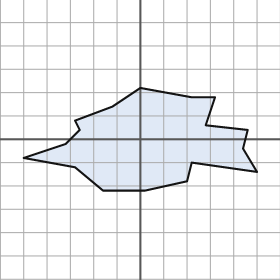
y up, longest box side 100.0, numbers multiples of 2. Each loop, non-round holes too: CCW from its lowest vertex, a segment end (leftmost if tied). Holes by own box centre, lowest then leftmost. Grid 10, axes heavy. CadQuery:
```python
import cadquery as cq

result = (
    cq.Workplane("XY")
    .moveTo(-16.0, -22.0)
    .lineTo(2.0, -22.0)
    .lineTo(20.0, -18.0)
    .lineTo(22.0, -10.0)
    .lineTo(50.0, -14.0)
    .lineTo(44.0, -4.0)
    .lineTo(46.0, 4.0)
    .lineTo(28.0, 6.0)
    .lineTo(32.0, 18.0)
    .lineTo(22.0, 18.0)
    .lineTo(0.0, 22.0)
    .lineTo(-12.0, 14.0)
    .lineTo(-28.0, 8.0)
    .lineTo(-26.0, 4.0)
    .lineTo(-32.0, -2.0)
    .lineTo(-50.0, -8.0)
    .lineTo(-28.0, -12.0)
    .close()
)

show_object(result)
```